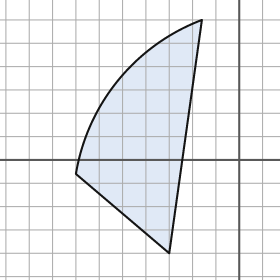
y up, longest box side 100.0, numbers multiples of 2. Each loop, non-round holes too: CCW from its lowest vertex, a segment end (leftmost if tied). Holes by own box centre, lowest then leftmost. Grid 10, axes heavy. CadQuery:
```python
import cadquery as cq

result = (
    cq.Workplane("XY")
    .moveTo(-30.0, -40.0)
    .lineTo(-16.0, 60.0)
    .threePointArc((-52.0, 34.0), (-70.0, -6.0))
    .close()
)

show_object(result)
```